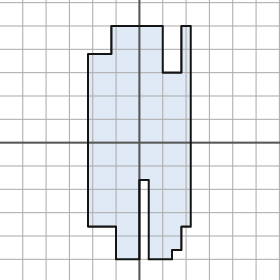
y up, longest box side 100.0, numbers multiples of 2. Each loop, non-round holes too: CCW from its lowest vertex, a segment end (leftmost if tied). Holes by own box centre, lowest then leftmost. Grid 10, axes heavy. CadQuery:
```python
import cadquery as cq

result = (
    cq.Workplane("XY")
    .moveTo(-10.0, -50.0)
    .lineTo(0.0, -50.0)
    .lineTo(0.0, -16.0)
    .lineTo(4.0, -16.0)
    .lineTo(4.0, -50.0)
    .lineTo(14.0, -50.0)
    .lineTo(14.0, -46.0)
    .lineTo(18.0, -46.0)
    .lineTo(18.0, -36.0)
    .lineTo(22.0, -36.0)
    .lineTo(22.0, 50.0)
    .lineTo(18.0, 50.0)
    .lineTo(18.0, 30.0)
    .lineTo(10.0, 30.0)
    .lineTo(10.0, 50.0)
    .lineTo(-12.0, 50.0)
    .lineTo(-12.0, 38.0)
    .lineTo(-22.0, 38.0)
    .lineTo(-22.0, -36.0)
    .lineTo(-10.0, -36.0)
    .close()
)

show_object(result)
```